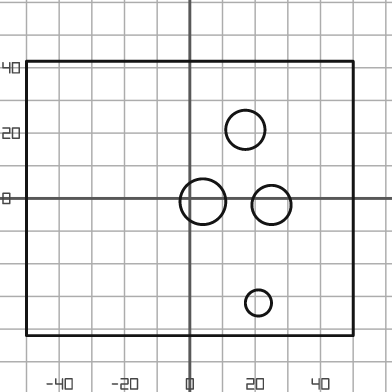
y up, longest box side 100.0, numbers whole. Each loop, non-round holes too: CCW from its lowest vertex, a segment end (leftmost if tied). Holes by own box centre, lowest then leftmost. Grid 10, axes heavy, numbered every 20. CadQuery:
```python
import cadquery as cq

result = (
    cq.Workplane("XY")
    .moveTo(-50.0, -42.0)
    .lineTo(50.0, -42.0)
    .lineTo(50.0, 42.0)
    .lineTo(-50.0, 42.0)
    .close()
    .moveTo(21.0, -32.0)
    .circle(4.0)
    .moveTo(25.0, -2.0)
    .circle(6.0)
    .moveTo(4.0, -1.0)
    .circle(7.0)
    .moveTo(17.0, 21.0)
    .circle(6.0)
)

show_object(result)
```